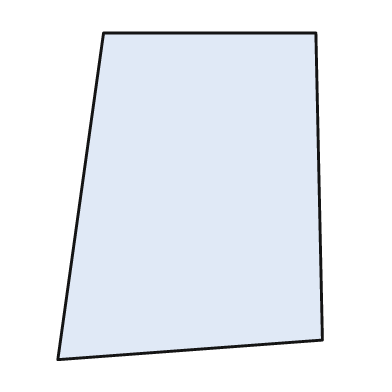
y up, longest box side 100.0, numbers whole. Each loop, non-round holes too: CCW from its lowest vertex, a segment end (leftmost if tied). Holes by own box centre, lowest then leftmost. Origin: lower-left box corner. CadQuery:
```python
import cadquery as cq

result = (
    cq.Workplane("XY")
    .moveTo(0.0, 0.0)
    .lineTo(81.0, 6.0)
    .lineTo(79.0, 100.0)
    .lineTo(14.0, 100.0)
    .close()
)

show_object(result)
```